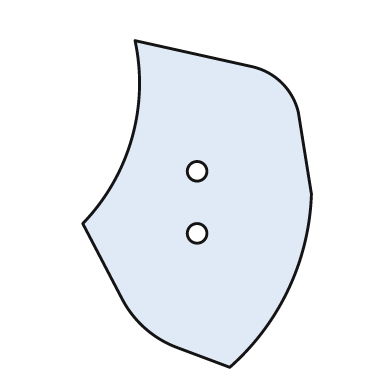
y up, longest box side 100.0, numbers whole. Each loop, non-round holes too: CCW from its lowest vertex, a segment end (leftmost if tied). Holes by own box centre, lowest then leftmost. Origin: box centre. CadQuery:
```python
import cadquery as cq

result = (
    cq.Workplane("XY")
    .moveTo(10.0, -50.0)
    .threePointArc((28.0, -26.0), (35.0, 3.0))
    .lineTo(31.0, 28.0)
    .threePointArc((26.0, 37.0), (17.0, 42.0))
    .lineTo(-19.0, 50.0)
    .threePointArc((-20.0, 20.0), (-35.0, -6.0))
    .lineTo(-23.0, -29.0)
    .threePointArc((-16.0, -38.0), (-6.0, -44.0))
    .close()
    .moveTo(0.0, -9.0)
    .circle(3.0)
    .moveTo(0.0, 10.0)
    .circle(3.0)
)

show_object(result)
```